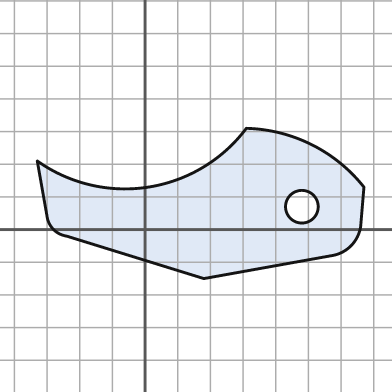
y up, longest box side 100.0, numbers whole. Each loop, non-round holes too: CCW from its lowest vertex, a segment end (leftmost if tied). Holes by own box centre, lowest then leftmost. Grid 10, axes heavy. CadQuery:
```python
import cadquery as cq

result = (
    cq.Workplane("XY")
    .moveTo(18.0, -15.0)
    .lineTo(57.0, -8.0)
    .threePointArc((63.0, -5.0), (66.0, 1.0))
    .lineTo(67.0, 13.0)
    .threePointArc((51.0, 26.0), (31.0, 31.0))
    .threePointArc((1.0, 13.0), (-33.0, 21.0))
    .lineTo(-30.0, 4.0)
    .threePointArc((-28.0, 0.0), (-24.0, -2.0))
    .close()
    .moveTo(48.0, 7.0)
    .circle(5.0)
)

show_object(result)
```